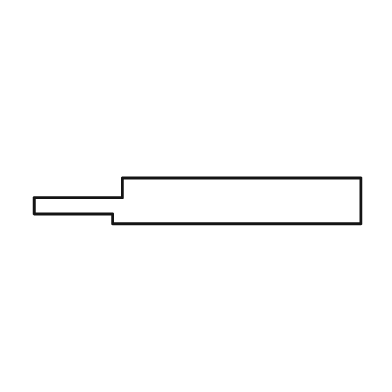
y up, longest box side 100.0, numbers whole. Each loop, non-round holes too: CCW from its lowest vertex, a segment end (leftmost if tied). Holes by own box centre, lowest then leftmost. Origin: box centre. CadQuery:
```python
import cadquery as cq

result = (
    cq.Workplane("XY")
    .moveTo(-26.0, -7.0)
    .lineTo(50.0, -7.0)
    .lineTo(50.0, 7.0)
    .lineTo(-23.0, 7.0)
    .lineTo(-23.0, 1.0)
    .lineTo(-50.0, 1.0)
    .lineTo(-50.0, -4.0)
    .lineTo(-26.0, -4.0)
    .close()
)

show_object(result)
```